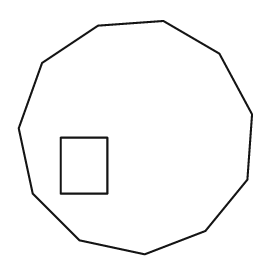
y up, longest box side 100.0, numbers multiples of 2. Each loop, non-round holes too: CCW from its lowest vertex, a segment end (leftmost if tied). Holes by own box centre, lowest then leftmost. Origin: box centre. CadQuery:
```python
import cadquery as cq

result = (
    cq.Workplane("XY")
    .moveTo(4.0, -50.0)
    .lineTo(30.0, -40.0)
    .lineTo(48.0, -18.0)
    .lineTo(50.0, 10.0)
    .lineTo(36.0, 36.0)
    .lineTo(12.0, 50.0)
    .lineTo(-16.0, 48.0)
    .lineTo(-40.0, 32.0)
    .lineTo(-50.0, 4.0)
    .lineTo(-44.0, -24.0)
    .lineTo(-24.0, -44.0)
    .close()
    .moveTo(-32.0, -24.0)
    .lineTo(-12.0, -24.0)
    .lineTo(-12.0, 0.0)
    .lineTo(-32.0, 0.0)
    .close()
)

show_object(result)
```